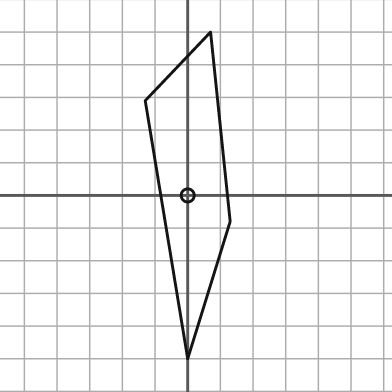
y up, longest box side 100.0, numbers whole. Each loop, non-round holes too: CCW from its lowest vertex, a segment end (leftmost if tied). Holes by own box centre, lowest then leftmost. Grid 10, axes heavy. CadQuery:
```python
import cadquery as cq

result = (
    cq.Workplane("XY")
    .moveTo(0.0, -50.0)
    .lineTo(13.0, -8.0)
    .lineTo(7.0, 50.0)
    .lineTo(-13.0, 29.0)
    .close()
    .moveTo(0.0, 0.0)
    .circle(2.0)
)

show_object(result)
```